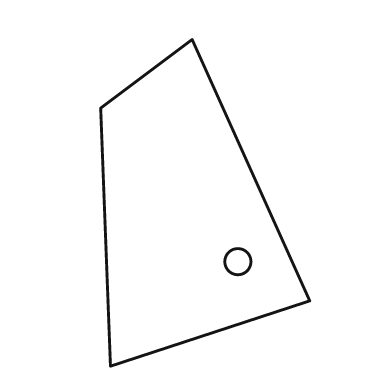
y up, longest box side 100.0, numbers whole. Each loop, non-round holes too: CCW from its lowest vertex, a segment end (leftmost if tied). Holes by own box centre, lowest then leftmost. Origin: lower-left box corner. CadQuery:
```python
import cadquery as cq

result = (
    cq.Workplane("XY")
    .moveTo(3.0, 0.0)
    .lineTo(64.0, 20.0)
    .lineTo(28.0, 100.0)
    .lineTo(0.0, 79.0)
    .close()
    .moveTo(42.0, 32.0)
    .circle(4.0)
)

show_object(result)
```